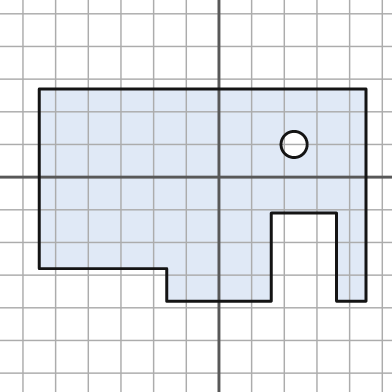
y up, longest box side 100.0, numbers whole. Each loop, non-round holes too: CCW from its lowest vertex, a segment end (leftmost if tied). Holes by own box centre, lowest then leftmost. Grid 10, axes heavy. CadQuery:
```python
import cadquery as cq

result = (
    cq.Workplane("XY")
    .moveTo(-16.0, -38.0)
    .lineTo(16.0, -38.0)
    .lineTo(16.0, -11.0)
    .lineTo(36.0, -11.0)
    .lineTo(36.0, -38.0)
    .lineTo(45.0, -38.0)
    .lineTo(45.0, 27.0)
    .lineTo(-55.0, 27.0)
    .lineTo(-55.0, -28.0)
    .lineTo(-16.0, -28.0)
    .close()
    .moveTo(23.0, 10.0)
    .circle(4.0)
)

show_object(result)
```